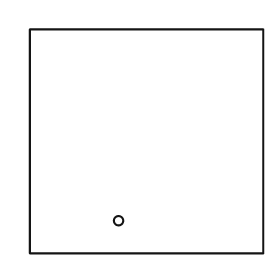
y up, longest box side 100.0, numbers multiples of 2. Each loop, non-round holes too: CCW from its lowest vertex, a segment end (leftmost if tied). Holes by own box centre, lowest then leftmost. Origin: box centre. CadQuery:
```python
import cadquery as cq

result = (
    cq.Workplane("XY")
    .moveTo(-50.0, -48.0)
    .lineTo(50.0, -48.0)
    .lineTo(50.0, 48.0)
    .lineTo(-50.0, 48.0)
    .close()
    .moveTo(-12.0, -34.0)
    .circle(2.0)
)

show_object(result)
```